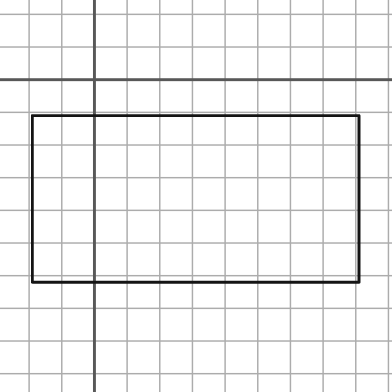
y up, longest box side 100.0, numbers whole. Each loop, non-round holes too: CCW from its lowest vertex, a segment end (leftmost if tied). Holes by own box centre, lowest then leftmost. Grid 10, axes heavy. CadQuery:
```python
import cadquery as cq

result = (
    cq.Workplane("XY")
    .moveTo(-19.0, -62.0)
    .lineTo(81.0, -62.0)
    .lineTo(81.0, -11.0)
    .lineTo(-19.0, -11.0)
    .close()
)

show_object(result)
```